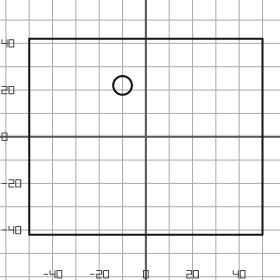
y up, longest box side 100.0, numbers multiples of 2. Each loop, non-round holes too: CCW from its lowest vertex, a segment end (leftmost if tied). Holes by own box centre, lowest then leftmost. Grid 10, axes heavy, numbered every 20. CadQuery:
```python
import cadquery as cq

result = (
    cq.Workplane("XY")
    .moveTo(-50.0, -42.0)
    .lineTo(50.0, -42.0)
    .lineTo(50.0, 42.0)
    .lineTo(-50.0, 42.0)
    .close()
    .moveTo(-10.0, 22.0)
    .circle(4.0)
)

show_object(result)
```